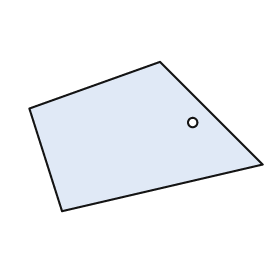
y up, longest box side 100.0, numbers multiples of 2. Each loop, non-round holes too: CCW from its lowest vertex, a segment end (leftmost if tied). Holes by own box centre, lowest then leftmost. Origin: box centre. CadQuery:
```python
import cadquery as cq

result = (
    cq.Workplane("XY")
    .moveTo(-36.0, -32.0)
    .lineTo(50.0, -12.0)
    .lineTo(6.0, 32.0)
    .lineTo(-50.0, 12.0)
    .close()
    .moveTo(20.0, 6.0)
    .circle(2.0)
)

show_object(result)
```